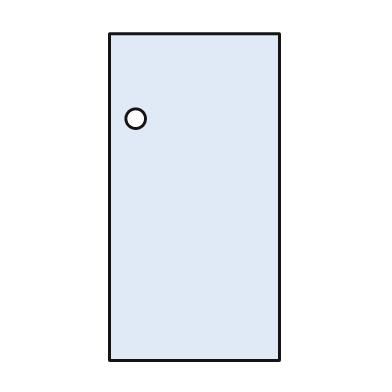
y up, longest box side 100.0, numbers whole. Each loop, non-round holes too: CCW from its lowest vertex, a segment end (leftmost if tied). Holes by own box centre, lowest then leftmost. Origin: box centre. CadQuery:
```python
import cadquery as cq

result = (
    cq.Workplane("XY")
    .moveTo(-26.0, -50.0)
    .lineTo(26.0, -50.0)
    .lineTo(26.0, 50.0)
    .lineTo(-26.0, 50.0)
    .close()
    .moveTo(-18.0, 24.0)
    .circle(3.0)
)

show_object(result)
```